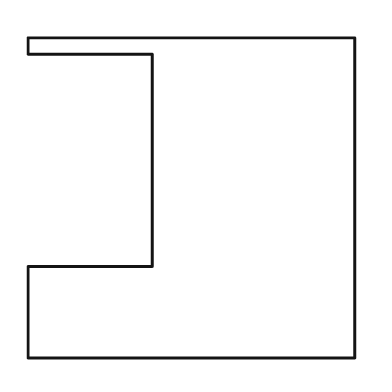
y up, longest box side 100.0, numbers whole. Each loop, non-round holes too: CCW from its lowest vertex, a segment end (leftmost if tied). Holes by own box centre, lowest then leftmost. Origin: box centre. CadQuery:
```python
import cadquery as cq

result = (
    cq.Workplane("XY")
    .moveTo(-50.0, -49.0)
    .lineTo(50.0, -49.0)
    .lineTo(50.0, 49.0)
    .lineTo(-50.0, 49.0)
    .lineTo(-50.0, 44.0)
    .lineTo(-12.0, 44.0)
    .lineTo(-12.0, -21.0)
    .lineTo(-50.0, -21.0)
    .close()
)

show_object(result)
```